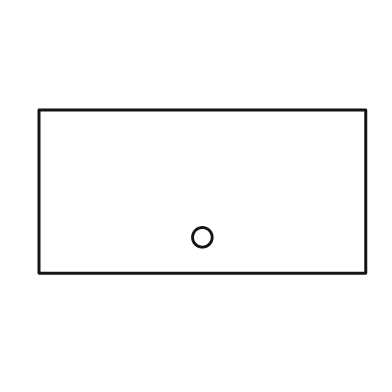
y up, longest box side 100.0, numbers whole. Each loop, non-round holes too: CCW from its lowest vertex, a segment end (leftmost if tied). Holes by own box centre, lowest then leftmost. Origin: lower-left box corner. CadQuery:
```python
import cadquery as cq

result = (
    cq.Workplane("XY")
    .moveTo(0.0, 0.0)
    .lineTo(100.0, 0.0)
    .lineTo(100.0, 50.0)
    .lineTo(0.0, 50.0)
    .close()
    .moveTo(50.0, 11.0)
    .circle(3.0)
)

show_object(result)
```